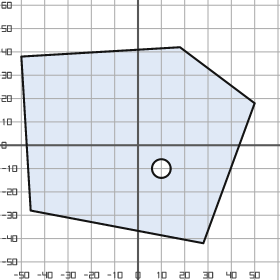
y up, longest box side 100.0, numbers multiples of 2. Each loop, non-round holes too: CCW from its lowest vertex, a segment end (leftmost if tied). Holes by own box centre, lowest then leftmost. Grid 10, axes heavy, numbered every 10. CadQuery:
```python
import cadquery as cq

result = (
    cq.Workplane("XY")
    .moveTo(28.0, -42.0)
    .lineTo(50.0, 18.0)
    .lineTo(18.0, 42.0)
    .lineTo(-50.0, 38.0)
    .lineTo(-46.0, -28.0)
    .close()
    .moveTo(10.0, -10.0)
    .circle(4.0)
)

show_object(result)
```